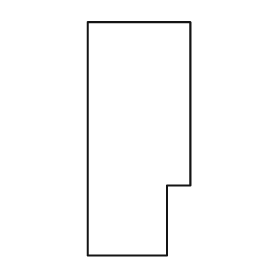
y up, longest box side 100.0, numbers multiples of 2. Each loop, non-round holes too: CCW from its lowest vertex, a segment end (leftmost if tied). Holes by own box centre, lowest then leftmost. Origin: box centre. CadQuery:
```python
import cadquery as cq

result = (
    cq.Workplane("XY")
    .moveTo(-22.0, -50.0)
    .lineTo(12.0, -50.0)
    .lineTo(12.0, -20.0)
    .lineTo(22.0, -20.0)
    .lineTo(22.0, 50.0)
    .lineTo(-22.0, 50.0)
    .close()
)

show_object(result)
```